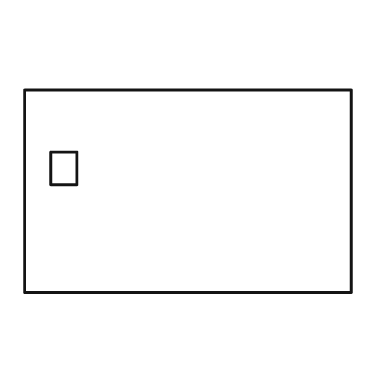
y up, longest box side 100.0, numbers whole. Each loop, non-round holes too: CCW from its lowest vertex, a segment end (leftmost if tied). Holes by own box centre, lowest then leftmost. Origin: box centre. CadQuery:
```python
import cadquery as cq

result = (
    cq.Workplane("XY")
    .moveTo(-50.0, -31.0)
    .lineTo(50.0, -31.0)
    .lineTo(50.0, 31.0)
    .lineTo(-50.0, 31.0)
    .close()
    .moveTo(-42.0, 2.0)
    .lineTo(-34.0, 2.0)
    .lineTo(-34.0, 12.0)
    .lineTo(-42.0, 12.0)
    .close()
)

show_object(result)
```